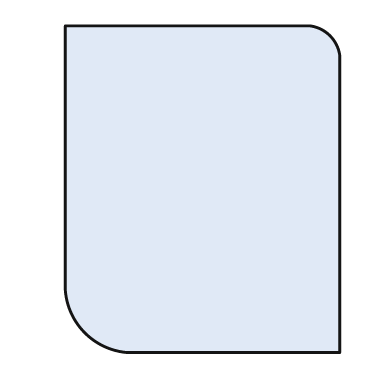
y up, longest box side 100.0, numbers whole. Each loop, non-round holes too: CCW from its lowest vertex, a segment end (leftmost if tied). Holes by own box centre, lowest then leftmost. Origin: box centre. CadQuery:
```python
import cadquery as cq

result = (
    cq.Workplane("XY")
    .moveTo(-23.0, -50.0)
    .lineTo(42.0, -50.0)
    .lineTo(42.0, 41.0)
    .threePointArc((39.0, 47.0), (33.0, 50.0))
    .lineTo(-42.0, 50.0)
    .lineTo(-42.0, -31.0)
    .threePointArc((-36.0, -44.0), (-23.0, -50.0))
    .close()
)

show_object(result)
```